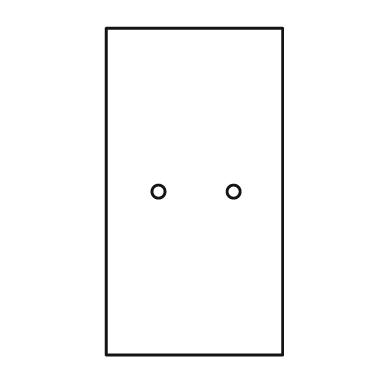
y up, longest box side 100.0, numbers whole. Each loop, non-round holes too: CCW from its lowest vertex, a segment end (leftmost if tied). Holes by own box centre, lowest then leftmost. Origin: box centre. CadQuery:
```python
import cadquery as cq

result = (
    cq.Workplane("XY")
    .moveTo(-27.0, -50.0)
    .lineTo(27.0, -50.0)
    .lineTo(27.0, 50.0)
    .lineTo(-27.0, 50.0)
    .close()
    .moveTo(-11.0, 0.0)
    .circle(2.0)
    .moveTo(12.0, 0.0)
    .circle(2.0)
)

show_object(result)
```